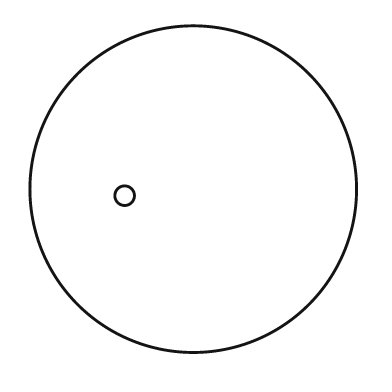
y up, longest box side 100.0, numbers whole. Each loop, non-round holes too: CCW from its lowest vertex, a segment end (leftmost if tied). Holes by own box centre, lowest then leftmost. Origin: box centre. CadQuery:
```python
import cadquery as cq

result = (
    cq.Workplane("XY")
    .moveTo(0.0, 0.0)
    .circle(50.0)
    .moveTo(-21.0, -2.0)
    .circle(3.0)
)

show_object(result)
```